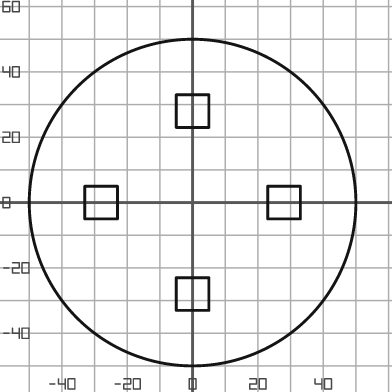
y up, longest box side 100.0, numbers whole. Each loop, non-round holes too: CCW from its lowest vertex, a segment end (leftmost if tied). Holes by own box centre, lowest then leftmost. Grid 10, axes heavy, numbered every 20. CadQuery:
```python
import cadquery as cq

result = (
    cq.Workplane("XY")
    .moveTo(0.0, 0.0)
    .circle(50.0)
    .moveTo(-5.0, -33.0)
    .lineTo(5.0, -33.0)
    .lineTo(5.0, -23.0)
    .lineTo(-5.0, -23.0)
    .close()
    .moveTo(-33.0, -5.0)
    .lineTo(-23.0, -5.0)
    .lineTo(-23.0, 5.0)
    .lineTo(-33.0, 5.0)
    .close()
    .moveTo(23.0, -5.0)
    .lineTo(33.0, -5.0)
    .lineTo(33.0, 5.0)
    .lineTo(23.0, 5.0)
    .close()
    .moveTo(-5.0, 23.0)
    .lineTo(5.0, 23.0)
    .lineTo(5.0, 33.0)
    .lineTo(-5.0, 33.0)
    .close()
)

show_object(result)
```